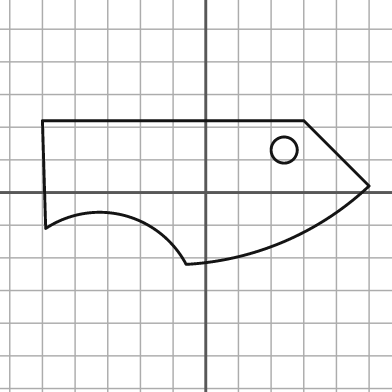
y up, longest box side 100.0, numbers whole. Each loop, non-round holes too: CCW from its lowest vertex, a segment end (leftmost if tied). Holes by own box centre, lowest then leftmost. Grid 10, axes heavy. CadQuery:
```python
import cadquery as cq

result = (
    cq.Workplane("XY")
    .moveTo(-6.0, -22.0)
    .threePointArc((24.0, -15.0), (50.0, 2.0))
    .lineTo(30.0, 22.0)
    .lineTo(-50.0, 22.0)
    .lineTo(-49.0, -11.0)
    .threePointArc((-25.0, -7.0), (-6.0, -22.0))
    .close()
    .moveTo(24.0, 13.0)
    .circle(4.0)
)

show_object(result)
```